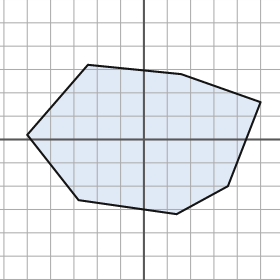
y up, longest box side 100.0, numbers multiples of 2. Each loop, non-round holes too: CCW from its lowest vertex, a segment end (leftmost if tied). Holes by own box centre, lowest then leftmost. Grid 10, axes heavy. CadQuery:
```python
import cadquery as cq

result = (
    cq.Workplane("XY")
    .moveTo(14.0, -32.0)
    .lineTo(36.0, -20.0)
    .lineTo(50.0, 16.0)
    .lineTo(16.0, 28.0)
    .lineTo(-24.0, 32.0)
    .lineTo(-50.0, 2.0)
    .lineTo(-28.0, -26.0)
    .close()
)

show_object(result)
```